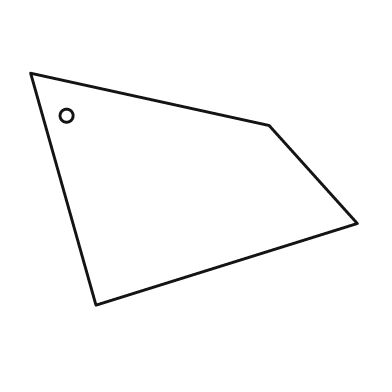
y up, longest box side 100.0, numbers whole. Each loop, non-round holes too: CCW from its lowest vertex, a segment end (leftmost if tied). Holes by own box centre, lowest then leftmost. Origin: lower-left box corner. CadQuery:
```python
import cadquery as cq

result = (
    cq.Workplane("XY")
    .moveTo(20.0, 0.0)
    .lineTo(100.0, 25.0)
    .lineTo(73.0, 55.0)
    .lineTo(0.0, 71.0)
    .close()
    .moveTo(11.0, 58.0)
    .circle(2.0)
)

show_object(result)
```